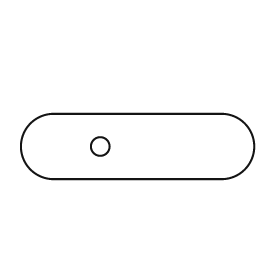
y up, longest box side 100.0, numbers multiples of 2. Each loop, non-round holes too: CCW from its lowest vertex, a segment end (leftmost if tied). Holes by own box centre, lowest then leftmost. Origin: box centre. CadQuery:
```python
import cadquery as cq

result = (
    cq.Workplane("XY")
    .moveTo(-36.0, -14.0)
    .lineTo(36.0, -14.0)
    .threePointArc((50.0, 0.0), (36.0, 14.0))
    .lineTo(-36.0, 14.0)
    .threePointArc((-50.0, 0.0), (-36.0, -14.0))
    .close()
    .moveTo(-16.0, 0.0)
    .circle(4.0)
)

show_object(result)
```